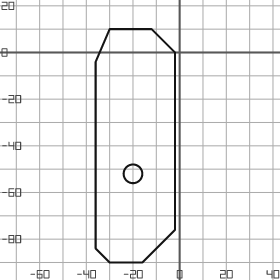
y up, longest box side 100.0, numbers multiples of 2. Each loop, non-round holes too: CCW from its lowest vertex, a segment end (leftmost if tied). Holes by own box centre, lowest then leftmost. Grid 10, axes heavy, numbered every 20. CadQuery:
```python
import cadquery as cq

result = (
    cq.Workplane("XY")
    .moveTo(-30.0, -90.0)
    .lineTo(-16.0, -90.0)
    .lineTo(-2.0, -76.0)
    .lineTo(-2.0, 0.0)
    .lineTo(-12.0, 10.0)
    .lineTo(-30.0, 10.0)
    .lineTo(-36.0, -4.0)
    .lineTo(-36.0, -84.0)
    .close()
    .moveTo(-20.0, -52.0)
    .circle(4.0)
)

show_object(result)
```